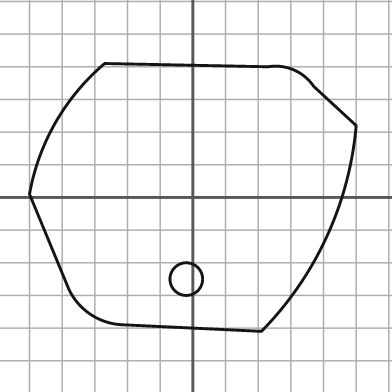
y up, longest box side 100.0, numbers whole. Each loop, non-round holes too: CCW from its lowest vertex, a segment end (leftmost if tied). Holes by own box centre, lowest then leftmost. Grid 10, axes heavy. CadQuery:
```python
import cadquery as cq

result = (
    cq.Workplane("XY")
    .moveTo(21.0, -41.0)
    .threePointArc((41.0, -12.0), (50.0, 22.0))
    .lineTo(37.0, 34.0)
    .threePointArc((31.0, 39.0), (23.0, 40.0))
    .lineTo(-27.0, 41.0)
    .threePointArc((-42.0, 23.0), (-50.0, 1.0))
    .lineTo(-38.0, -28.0)
    .threePointArc((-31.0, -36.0), (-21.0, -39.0))
    .close()
    .moveTo(-2.0, -25.0)
    .circle(5.0)
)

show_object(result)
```